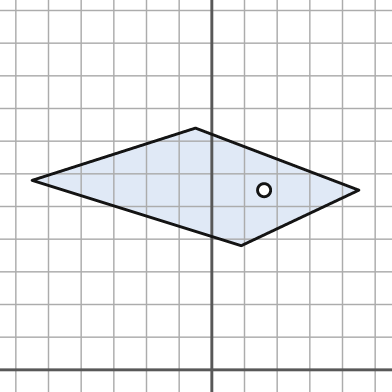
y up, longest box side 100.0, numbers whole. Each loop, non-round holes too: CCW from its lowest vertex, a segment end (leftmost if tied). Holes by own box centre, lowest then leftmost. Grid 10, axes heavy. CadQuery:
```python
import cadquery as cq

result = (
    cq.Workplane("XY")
    .moveTo(9.0, 38.0)
    .lineTo(45.0, 55.0)
    .lineTo(-5.0, 74.0)
    .lineTo(-55.0, 58.0)
    .close()
    .moveTo(16.0, 55.0)
    .circle(2.0)
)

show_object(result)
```